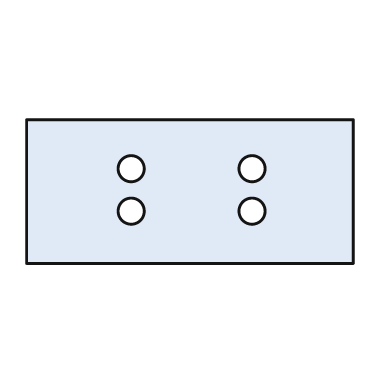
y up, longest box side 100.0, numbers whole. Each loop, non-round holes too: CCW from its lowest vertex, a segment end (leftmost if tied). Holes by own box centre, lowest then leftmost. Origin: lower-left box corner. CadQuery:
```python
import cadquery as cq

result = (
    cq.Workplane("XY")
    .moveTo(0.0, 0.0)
    .lineTo(100.0, 0.0)
    .lineTo(100.0, 44.0)
    .lineTo(0.0, 44.0)
    .close()
    .moveTo(32.0, 16.0)
    .circle(4.0)
    .moveTo(69.0, 16.0)
    .circle(4.0)
    .moveTo(32.0, 29.0)
    .circle(4.0)
    .moveTo(69.0, 29.0)
    .circle(4.0)
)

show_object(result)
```